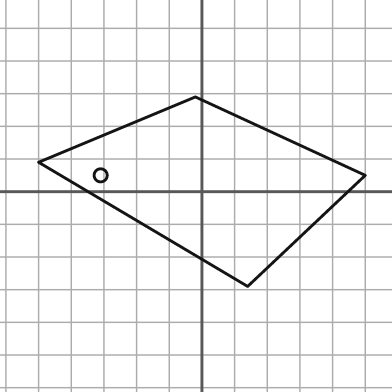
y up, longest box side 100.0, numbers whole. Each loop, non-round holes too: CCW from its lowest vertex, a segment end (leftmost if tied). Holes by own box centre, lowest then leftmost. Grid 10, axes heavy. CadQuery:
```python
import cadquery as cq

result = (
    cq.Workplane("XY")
    .moveTo(14.0, -29.0)
    .lineTo(50.0, 5.0)
    .lineTo(-2.0, 29.0)
    .lineTo(-50.0, 9.0)
    .close()
    .moveTo(-31.0, 5.0)
    .circle(2.0)
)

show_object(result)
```